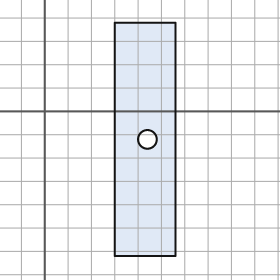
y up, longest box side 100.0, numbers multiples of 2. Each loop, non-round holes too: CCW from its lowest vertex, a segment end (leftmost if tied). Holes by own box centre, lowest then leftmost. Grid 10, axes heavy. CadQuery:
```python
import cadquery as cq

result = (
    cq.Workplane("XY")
    .moveTo(30.0, -62.0)
    .lineTo(56.0, -62.0)
    .lineTo(56.0, 38.0)
    .lineTo(30.0, 38.0)
    .close()
    .moveTo(44.0, -12.0)
    .circle(4.0)
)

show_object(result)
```